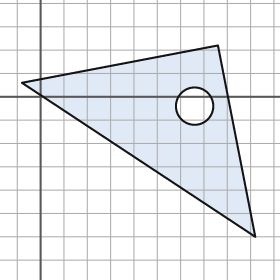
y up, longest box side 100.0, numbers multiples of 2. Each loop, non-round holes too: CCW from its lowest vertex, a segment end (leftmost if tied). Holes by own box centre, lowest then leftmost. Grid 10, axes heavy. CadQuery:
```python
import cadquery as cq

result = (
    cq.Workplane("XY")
    .moveTo(92.0, -60.0)
    .lineTo(76.0, 22.0)
    .lineTo(-8.0, 6.0)
    .close()
    .moveTo(66.0, -4.0)
    .circle(8.0)
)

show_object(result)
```